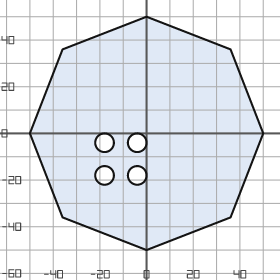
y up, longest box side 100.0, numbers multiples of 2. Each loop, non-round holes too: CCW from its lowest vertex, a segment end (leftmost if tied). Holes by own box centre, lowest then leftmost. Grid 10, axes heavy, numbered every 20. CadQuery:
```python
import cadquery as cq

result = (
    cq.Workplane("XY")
    .moveTo(0.0, -50.0)
    .lineTo(36.0, -36.0)
    .lineTo(50.0, 0.0)
    .lineTo(36.0, 36.0)
    .lineTo(0.0, 50.0)
    .lineTo(-36.0, 36.0)
    .lineTo(-50.0, 0.0)
    .lineTo(-36.0, -36.0)
    .close()
    .moveTo(-18.0, -18.0)
    .circle(4.0)
    .moveTo(-4.0, -18.0)
    .circle(4.0)
    .moveTo(-18.0, -4.0)
    .circle(4.0)
    .moveTo(-4.0, -4.0)
    .circle(4.0)
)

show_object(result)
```